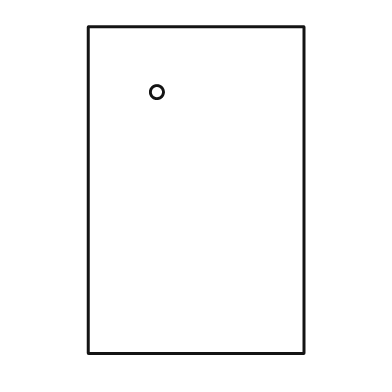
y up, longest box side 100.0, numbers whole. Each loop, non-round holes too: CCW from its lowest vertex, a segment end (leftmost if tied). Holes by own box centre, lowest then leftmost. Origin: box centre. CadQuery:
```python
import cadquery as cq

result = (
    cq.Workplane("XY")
    .moveTo(-33.0, -50.0)
    .lineTo(33.0, -50.0)
    .lineTo(33.0, 50.0)
    .lineTo(-33.0, 50.0)
    .close()
    .moveTo(-12.0, 30.0)
    .circle(2.0)
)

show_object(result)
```